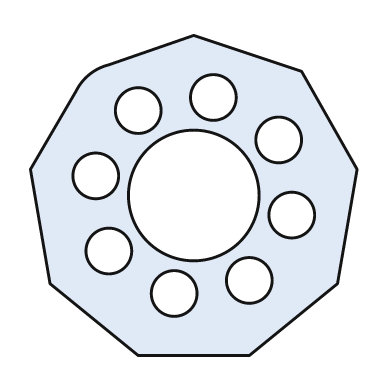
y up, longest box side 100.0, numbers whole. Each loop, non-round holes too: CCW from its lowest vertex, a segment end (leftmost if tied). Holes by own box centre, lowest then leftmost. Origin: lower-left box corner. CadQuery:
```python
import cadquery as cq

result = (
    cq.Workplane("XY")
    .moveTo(33.0, 0.0)
    .lineTo(67.0, 0.0)
    .lineTo(94.0, 22.0)
    .lineTo(100.0, 57.0)
    .lineTo(83.0, 87.0)
    .lineTo(50.0, 98.0)
    .lineTo(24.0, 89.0)
    .threePointArc((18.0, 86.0), (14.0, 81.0))
    .lineTo(0.0, 57.0)
    .lineTo(6.0, 22.0)
    .close()
    .moveTo(44.0, 19.0)
    .circle(7.0)
    .moveTo(67.0, 23.0)
    .circle(7.0)
    .moveTo(24.0, 32.0)
    .circle(7.0)
    .moveTo(80.0, 43.0)
    .circle(7.0)
    .moveTo(50.0, 49.0)
    .circle(20.0)
    .moveTo(20.0, 55.0)
    .circle(7.0)
    .moveTo(76.0, 66.0)
    .circle(7.0)
    .moveTo(33.0, 75.0)
    .circle(7.0)
    .moveTo(56.0, 79.0)
    .circle(7.0)
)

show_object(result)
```